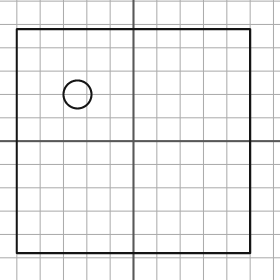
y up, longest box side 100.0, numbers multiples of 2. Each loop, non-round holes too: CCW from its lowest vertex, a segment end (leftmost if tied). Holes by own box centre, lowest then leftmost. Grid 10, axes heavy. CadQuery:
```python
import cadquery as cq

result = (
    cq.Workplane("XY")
    .moveTo(-50.0, -48.0)
    .lineTo(50.0, -48.0)
    .lineTo(50.0, 48.0)
    .lineTo(-50.0, 48.0)
    .close()
    .moveTo(-24.0, 20.0)
    .circle(6.0)
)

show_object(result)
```